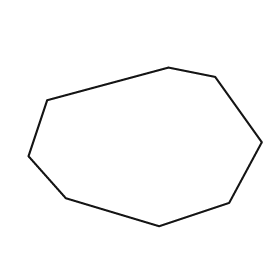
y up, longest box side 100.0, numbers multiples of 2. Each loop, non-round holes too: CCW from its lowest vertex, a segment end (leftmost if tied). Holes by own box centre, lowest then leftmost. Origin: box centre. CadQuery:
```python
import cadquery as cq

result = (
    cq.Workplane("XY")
    .moveTo(6.0, -34.0)
    .lineTo(36.0, -24.0)
    .lineTo(50.0, 2.0)
    .lineTo(30.0, 30.0)
    .lineTo(10.0, 34.0)
    .lineTo(-42.0, 20.0)
    .lineTo(-50.0, -4.0)
    .lineTo(-34.0, -22.0)
    .close()
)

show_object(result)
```